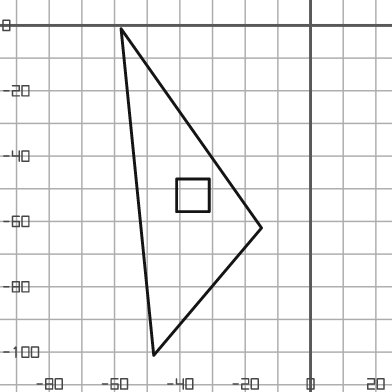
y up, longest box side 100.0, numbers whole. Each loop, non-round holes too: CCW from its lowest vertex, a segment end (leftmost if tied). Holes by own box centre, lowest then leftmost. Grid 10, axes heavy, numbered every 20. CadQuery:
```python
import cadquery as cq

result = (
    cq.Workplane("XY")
    .moveTo(-48.0, -101.0)
    .lineTo(-15.0, -62.0)
    .lineTo(-58.0, -1.0)
    .close()
    .moveTo(-41.0, -57.0)
    .lineTo(-31.0, -57.0)
    .lineTo(-31.0, -47.0)
    .lineTo(-41.0, -47.0)
    .close()
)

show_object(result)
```